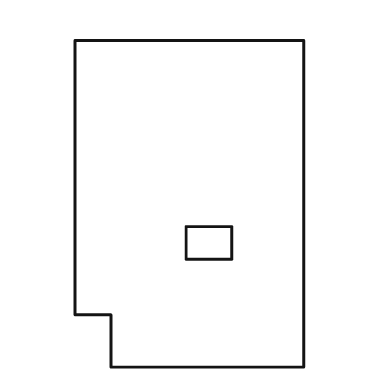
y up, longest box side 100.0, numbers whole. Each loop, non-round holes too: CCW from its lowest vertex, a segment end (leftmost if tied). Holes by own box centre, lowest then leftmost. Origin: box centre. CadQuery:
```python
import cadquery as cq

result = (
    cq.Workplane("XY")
    .moveTo(-24.0, -50.0)
    .lineTo(35.0, -50.0)
    .lineTo(35.0, 50.0)
    .lineTo(-35.0, 50.0)
    .lineTo(-35.0, -34.0)
    .lineTo(-24.0, -34.0)
    .close()
    .moveTo(-1.0, -17.0)
    .lineTo(13.0, -17.0)
    .lineTo(13.0, -7.0)
    .lineTo(-1.0, -7.0)
    .close()
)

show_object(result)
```